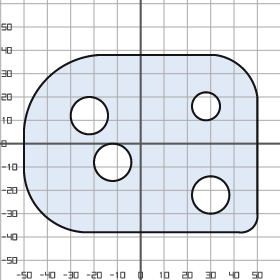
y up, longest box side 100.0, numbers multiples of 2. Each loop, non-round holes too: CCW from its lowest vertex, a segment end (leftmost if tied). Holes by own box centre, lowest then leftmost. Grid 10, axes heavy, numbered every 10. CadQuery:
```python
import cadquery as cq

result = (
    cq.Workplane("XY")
    .moveTo(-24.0, -38.0)
    .lineTo(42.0, -38.0)
    .threePointArc((48.0, -36.0), (50.0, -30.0))
    .lineTo(50.0, 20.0)
    .threePointArc((44.0, 32.0), (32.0, 38.0))
    .lineTo(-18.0, 38.0)
    .threePointArc((-40.0, 28.0), (-50.0, 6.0))
    .lineTo(-50.0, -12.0)
    .threePointArc((-42.0, -30.0), (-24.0, -38.0))
    .close()
    .moveTo(30.0, -22.0)
    .circle(8.0)
    .moveTo(-12.0, -8.0)
    .circle(8.0)
    .moveTo(-22.0, 12.0)
    .circle(8.0)
    .moveTo(28.0, 16.0)
    .circle(6.0)
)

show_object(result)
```